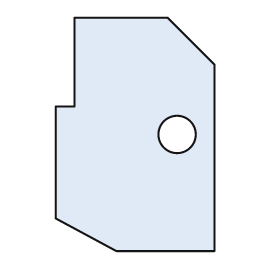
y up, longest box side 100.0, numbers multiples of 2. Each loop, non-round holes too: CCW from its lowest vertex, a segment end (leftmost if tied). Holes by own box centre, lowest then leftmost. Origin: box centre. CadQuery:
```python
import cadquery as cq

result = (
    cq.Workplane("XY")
    .moveTo(-8.0, -50.0)
    .lineTo(34.0, -50.0)
    .lineTo(34.0, 30.0)
    .lineTo(14.0, 50.0)
    .lineTo(-26.0, 50.0)
    .lineTo(-26.0, 12.0)
    .lineTo(-34.0, 12.0)
    .lineTo(-34.0, -36.0)
    .close()
    .moveTo(18.0, 0.0)
    .circle(8.0)
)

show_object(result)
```